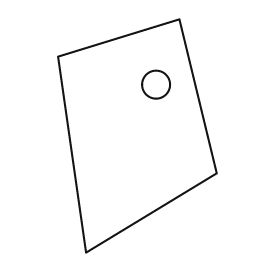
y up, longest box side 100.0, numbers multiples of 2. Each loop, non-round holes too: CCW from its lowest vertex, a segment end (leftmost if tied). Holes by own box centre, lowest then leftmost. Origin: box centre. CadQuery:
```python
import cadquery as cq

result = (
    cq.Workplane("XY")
    .moveTo(-22.0, -50.0)
    .lineTo(34.0, -16.0)
    .lineTo(18.0, 50.0)
    .lineTo(-34.0, 34.0)
    .close()
    .moveTo(8.0, 22.0)
    .circle(6.0)
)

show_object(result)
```